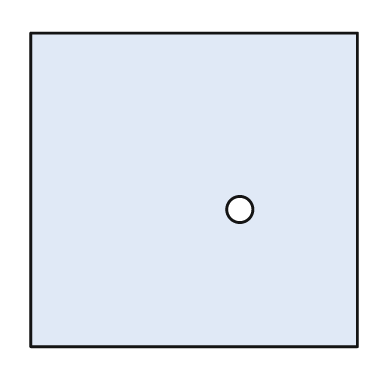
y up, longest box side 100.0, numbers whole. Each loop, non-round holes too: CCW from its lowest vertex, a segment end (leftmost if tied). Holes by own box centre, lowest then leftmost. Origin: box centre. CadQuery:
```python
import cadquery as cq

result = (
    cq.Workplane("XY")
    .moveTo(-50.0, -48.0)
    .lineTo(50.0, -48.0)
    .lineTo(50.0, 48.0)
    .lineTo(-50.0, 48.0)
    .close()
    .moveTo(14.0, -6.0)
    .circle(4.0)
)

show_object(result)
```